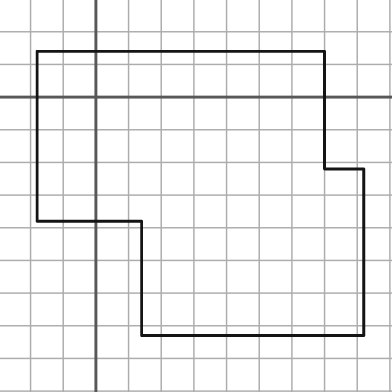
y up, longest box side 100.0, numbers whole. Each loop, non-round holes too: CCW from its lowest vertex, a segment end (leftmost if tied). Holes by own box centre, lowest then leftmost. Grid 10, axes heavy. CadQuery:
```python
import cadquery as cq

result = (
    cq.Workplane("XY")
    .moveTo(14.0, -73.0)
    .lineTo(82.0, -73.0)
    .lineTo(82.0, -22.0)
    .lineTo(70.0, -22.0)
    .lineTo(70.0, 14.0)
    .lineTo(-18.0, 14.0)
    .lineTo(-18.0, -38.0)
    .lineTo(14.0, -38.0)
    .close()
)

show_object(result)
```